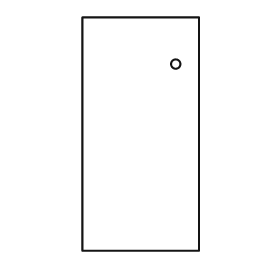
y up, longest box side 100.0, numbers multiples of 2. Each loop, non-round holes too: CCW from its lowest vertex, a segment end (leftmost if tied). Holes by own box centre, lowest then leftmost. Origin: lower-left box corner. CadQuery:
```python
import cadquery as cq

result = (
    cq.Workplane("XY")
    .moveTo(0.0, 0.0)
    .lineTo(50.0, 0.0)
    .lineTo(50.0, 100.0)
    .lineTo(0.0, 100.0)
    .close()
    .moveTo(40.0, 80.0)
    .circle(2.0)
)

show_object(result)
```